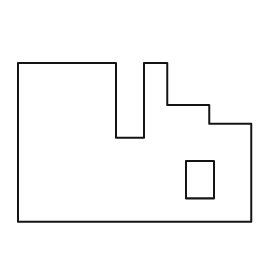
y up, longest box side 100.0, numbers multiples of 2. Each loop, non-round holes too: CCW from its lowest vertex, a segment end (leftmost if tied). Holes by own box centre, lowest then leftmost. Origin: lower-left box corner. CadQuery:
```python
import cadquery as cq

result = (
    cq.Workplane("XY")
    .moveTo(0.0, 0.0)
    .lineTo(100.0, 0.0)
    .lineTo(100.0, 42.0)
    .lineTo(82.0, 42.0)
    .lineTo(82.0, 50.0)
    .lineTo(64.0, 50.0)
    .lineTo(64.0, 68.0)
    .lineTo(54.0, 68.0)
    .lineTo(54.0, 36.0)
    .lineTo(42.0, 36.0)
    .lineTo(42.0, 68.0)
    .lineTo(0.0, 68.0)
    .close()
    .moveTo(72.0, 10.0)
    .lineTo(84.0, 10.0)
    .lineTo(84.0, 26.0)
    .lineTo(72.0, 26.0)
    .close()
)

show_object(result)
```